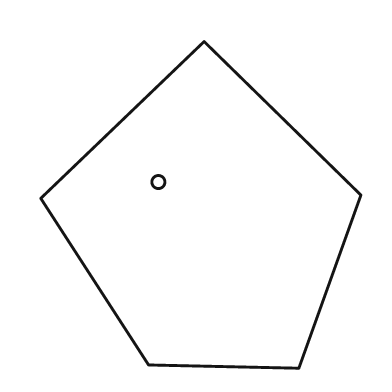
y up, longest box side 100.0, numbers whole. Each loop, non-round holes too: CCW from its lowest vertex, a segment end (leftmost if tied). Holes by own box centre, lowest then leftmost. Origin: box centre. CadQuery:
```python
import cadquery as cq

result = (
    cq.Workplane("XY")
    .moveTo(30.0, -50.0)
    .lineTo(49.0, 3.0)
    .lineTo(1.0, 50.0)
    .lineTo(-49.0, 2.0)
    .lineTo(-16.0, -49.0)
    .close()
    .moveTo(-13.0, 7.0)
    .circle(2.0)
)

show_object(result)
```